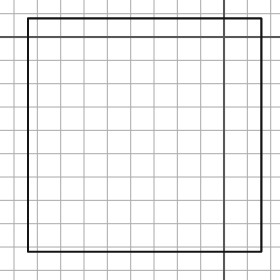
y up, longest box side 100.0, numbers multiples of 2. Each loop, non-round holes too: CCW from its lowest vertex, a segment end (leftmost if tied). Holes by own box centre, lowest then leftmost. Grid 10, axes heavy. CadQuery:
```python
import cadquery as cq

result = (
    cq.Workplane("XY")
    .moveTo(-84.0, -92.0)
    .lineTo(16.0, -92.0)
    .lineTo(16.0, 8.0)
    .lineTo(-84.0, 8.0)
    .close()
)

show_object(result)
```